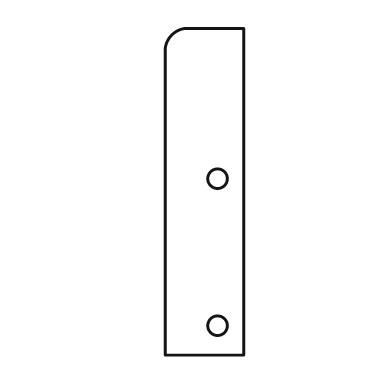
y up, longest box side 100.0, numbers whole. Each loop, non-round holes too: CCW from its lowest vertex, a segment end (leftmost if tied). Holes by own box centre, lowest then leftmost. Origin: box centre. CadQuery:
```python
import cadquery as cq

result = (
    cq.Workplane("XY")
    .moveTo(-12.0, -50.0)
    .lineTo(12.0, -50.0)
    .lineTo(12.0, 50.0)
    .lineTo(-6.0, 50.0)
    .threePointArc((-10.0, 48.0), (-12.0, 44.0))
    .close()
    .moveTo(4.0, -41.0)
    .circle(3.0)
    .moveTo(4.0, 4.0)
    .circle(3.0)
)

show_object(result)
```